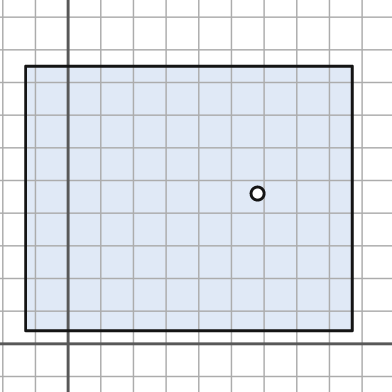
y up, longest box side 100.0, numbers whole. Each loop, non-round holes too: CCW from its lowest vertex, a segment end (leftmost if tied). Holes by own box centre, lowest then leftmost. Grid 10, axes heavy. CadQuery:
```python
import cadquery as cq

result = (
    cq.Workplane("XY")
    .moveTo(-13.0, 4.0)
    .lineTo(87.0, 4.0)
    .lineTo(87.0, 85.0)
    .lineTo(-13.0, 85.0)
    .close()
    .moveTo(58.0, 46.0)
    .circle(2.0)
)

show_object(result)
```